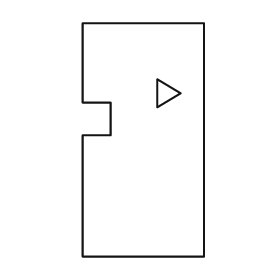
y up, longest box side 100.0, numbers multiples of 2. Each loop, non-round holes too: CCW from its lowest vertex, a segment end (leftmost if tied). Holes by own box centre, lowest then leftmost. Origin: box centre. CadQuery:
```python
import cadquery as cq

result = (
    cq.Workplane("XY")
    .moveTo(-26.0, -50.0)
    .lineTo(26.0, -50.0)
    .lineTo(26.0, 50.0)
    .lineTo(-26.0, 50.0)
    .lineTo(-26.0, 16.0)
    .lineTo(-14.0, 16.0)
    .lineTo(-14.0, 2.0)
    .lineTo(-26.0, 2.0)
    .close()
    .moveTo(6.0, 14.0)
    .lineTo(16.0, 20.0)
    .lineTo(6.0, 26.0)
    .close()
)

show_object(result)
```